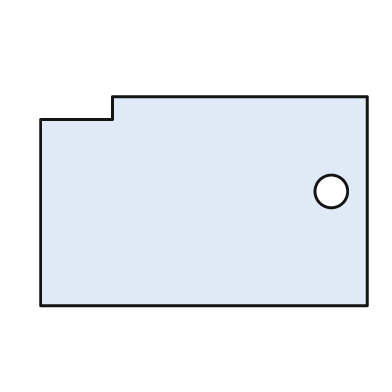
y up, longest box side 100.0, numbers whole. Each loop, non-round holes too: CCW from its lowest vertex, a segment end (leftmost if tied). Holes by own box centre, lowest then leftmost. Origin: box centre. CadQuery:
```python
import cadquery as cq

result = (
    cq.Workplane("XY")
    .moveTo(-50.0, -32.0)
    .lineTo(50.0, -32.0)
    .lineTo(50.0, 32.0)
    .lineTo(-28.0, 32.0)
    .lineTo(-28.0, 25.0)
    .lineTo(-50.0, 25.0)
    .close()
    .moveTo(39.0, 3.0)
    .circle(5.0)
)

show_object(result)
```